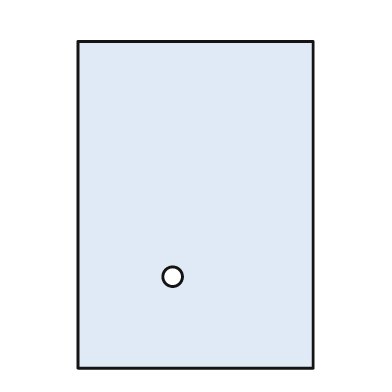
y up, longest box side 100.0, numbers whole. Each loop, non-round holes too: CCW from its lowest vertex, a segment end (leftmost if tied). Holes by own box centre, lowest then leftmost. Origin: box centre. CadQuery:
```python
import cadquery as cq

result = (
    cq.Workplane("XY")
    .moveTo(-36.0, -50.0)
    .lineTo(36.0, -50.0)
    .lineTo(36.0, 50.0)
    .lineTo(-36.0, 50.0)
    .close()
    .moveTo(-7.0, -22.0)
    .circle(3.0)
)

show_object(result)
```